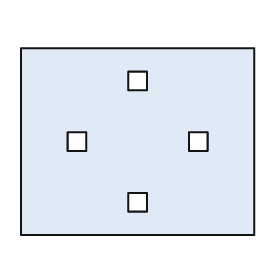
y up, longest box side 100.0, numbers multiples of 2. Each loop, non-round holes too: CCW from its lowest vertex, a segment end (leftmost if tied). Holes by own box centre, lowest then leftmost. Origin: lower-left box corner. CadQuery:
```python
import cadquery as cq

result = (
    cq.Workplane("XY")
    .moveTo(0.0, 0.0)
    .lineTo(100.0, 0.0)
    .lineTo(100.0, 80.0)
    .lineTo(0.0, 80.0)
    .close()
    .moveTo(46.0, 10.0)
    .lineTo(54.0, 10.0)
    .lineTo(54.0, 18.0)
    .lineTo(46.0, 18.0)
    .close()
    .moveTo(20.0, 36.0)
    .lineTo(28.0, 36.0)
    .lineTo(28.0, 44.0)
    .lineTo(20.0, 44.0)
    .close()
    .moveTo(72.0, 36.0)
    .lineTo(80.0, 36.0)
    .lineTo(80.0, 44.0)
    .lineTo(72.0, 44.0)
    .close()
    .moveTo(46.0, 62.0)
    .lineTo(54.0, 62.0)
    .lineTo(54.0, 70.0)
    .lineTo(46.0, 70.0)
    .close()
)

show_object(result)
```